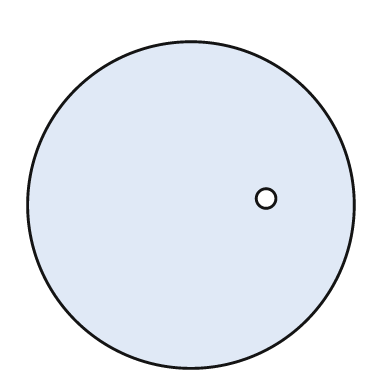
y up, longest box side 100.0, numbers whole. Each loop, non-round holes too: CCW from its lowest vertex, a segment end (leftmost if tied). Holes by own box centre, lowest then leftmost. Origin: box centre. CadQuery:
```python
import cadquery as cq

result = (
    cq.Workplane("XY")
    .moveTo(0.0, 0.0)
    .circle(50.0)
    .moveTo(23.0, 2.0)
    .circle(3.0)
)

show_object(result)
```